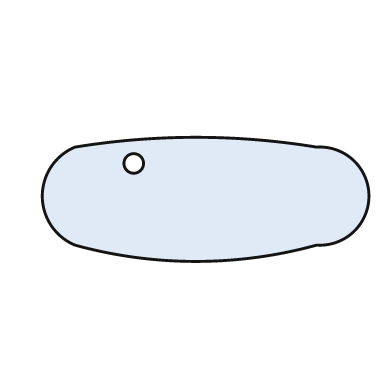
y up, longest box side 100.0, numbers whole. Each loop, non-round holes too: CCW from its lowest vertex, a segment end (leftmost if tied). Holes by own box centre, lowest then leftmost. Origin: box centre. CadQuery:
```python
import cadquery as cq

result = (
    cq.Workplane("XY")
    .moveTo(-40.0, -14.0)
    .threePointArc((-3.0, -19.0), (34.0, -14.0))
    .threePointArc((50.0, 1.0), (34.0, 16.0))
    .threePointArc((-3.0, 19.0), (-40.0, 16.0))
    .threePointArc((-50.0, 1.0), (-40.0, -14.0))
    .close()
    .moveTo(-22.0, 11.0)
    .circle(3.0)
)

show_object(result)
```